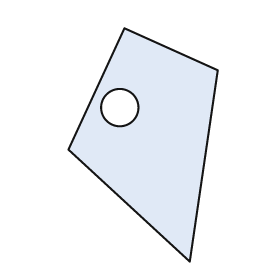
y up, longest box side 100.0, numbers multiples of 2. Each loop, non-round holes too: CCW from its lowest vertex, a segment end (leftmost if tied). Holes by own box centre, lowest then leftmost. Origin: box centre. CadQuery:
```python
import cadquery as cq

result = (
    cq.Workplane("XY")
    .moveTo(20.0, -50.0)
    .lineTo(32.0, 32.0)
    .lineTo(-8.0, 50.0)
    .lineTo(-32.0, -2.0)
    .close()
    .moveTo(-10.0, 16.0)
    .circle(8.0)
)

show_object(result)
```